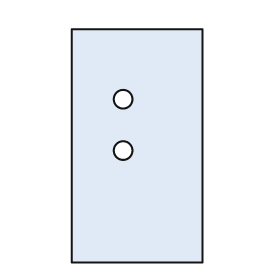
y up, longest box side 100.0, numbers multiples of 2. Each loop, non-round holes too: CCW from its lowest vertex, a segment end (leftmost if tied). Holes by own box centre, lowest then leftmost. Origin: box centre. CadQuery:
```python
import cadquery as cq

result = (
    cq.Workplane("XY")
    .moveTo(-28.0, -50.0)
    .lineTo(28.0, -50.0)
    .lineTo(28.0, 50.0)
    .lineTo(-28.0, 50.0)
    .close()
    .moveTo(-6.0, -2.0)
    .circle(4.0)
    .moveTo(-6.0, 20.0)
    .circle(4.0)
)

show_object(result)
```